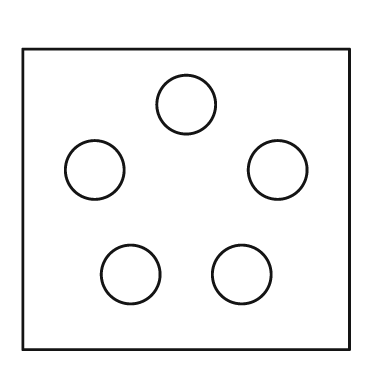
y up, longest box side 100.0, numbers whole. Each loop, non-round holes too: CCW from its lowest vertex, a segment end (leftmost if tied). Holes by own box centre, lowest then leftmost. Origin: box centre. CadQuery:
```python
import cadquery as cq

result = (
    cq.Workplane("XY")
    .moveTo(-50.0, -46.0)
    .lineTo(50.0, -46.0)
    .lineTo(50.0, 46.0)
    .lineTo(-50.0, 46.0)
    .close()
    .moveTo(-17.0, -23.0)
    .circle(9.0)
    .moveTo(17.0, -23.0)
    .circle(9.0)
    .moveTo(-28.0, 9.0)
    .circle(9.0)
    .moveTo(28.0, 9.0)
    .circle(9.0)
    .moveTo(0.0, 29.0)
    .circle(9.0)
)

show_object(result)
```